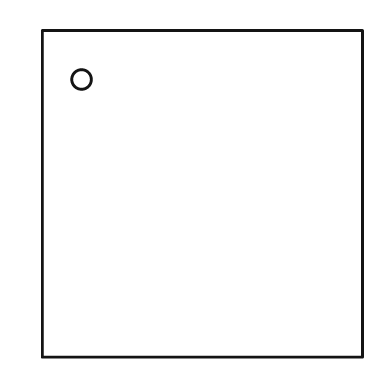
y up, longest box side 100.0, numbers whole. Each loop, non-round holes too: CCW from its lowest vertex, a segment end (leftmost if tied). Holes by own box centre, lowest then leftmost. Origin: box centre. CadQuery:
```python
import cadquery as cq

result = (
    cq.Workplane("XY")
    .moveTo(-49.0, -50.0)
    .lineTo(49.0, -50.0)
    .lineTo(49.0, 50.0)
    .lineTo(-49.0, 50.0)
    .close()
    .moveTo(-37.0, 35.0)
    .circle(3.0)
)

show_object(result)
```